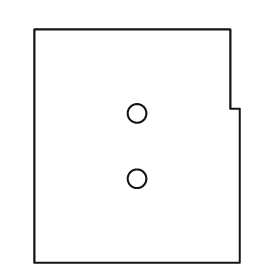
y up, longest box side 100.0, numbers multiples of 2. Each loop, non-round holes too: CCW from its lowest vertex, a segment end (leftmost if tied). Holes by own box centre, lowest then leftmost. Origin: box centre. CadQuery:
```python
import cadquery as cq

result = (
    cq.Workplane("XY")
    .moveTo(-44.0, -50.0)
    .lineTo(44.0, -50.0)
    .lineTo(44.0, 16.0)
    .lineTo(40.0, 16.0)
    .lineTo(40.0, 50.0)
    .lineTo(-44.0, 50.0)
    .close()
    .moveTo(0.0, -14.0)
    .circle(4.0)
    .moveTo(0.0, 14.0)
    .circle(4.0)
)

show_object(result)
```